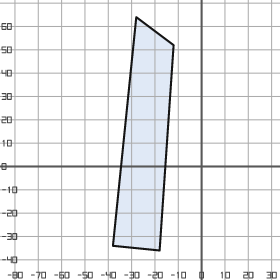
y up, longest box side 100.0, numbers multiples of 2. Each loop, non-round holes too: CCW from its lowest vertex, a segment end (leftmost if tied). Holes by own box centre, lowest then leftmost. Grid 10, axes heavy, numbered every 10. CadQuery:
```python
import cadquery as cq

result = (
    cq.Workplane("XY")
    .moveTo(-18.0, -36.0)
    .lineTo(-12.0, 52.0)
    .lineTo(-28.0, 64.0)
    .lineTo(-38.0, -34.0)
    .close()
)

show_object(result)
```